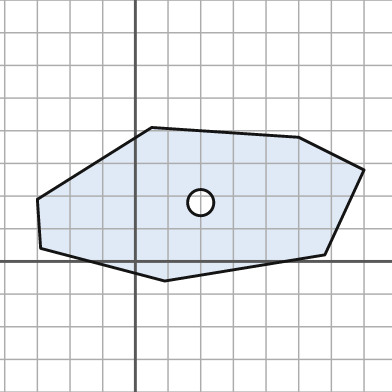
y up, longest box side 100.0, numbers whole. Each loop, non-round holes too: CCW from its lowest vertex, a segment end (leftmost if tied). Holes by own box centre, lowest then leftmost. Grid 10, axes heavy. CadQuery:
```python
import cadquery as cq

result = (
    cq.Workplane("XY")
    .moveTo(9.0, -6.0)
    .lineTo(58.0, 2.0)
    .lineTo(70.0, 28.0)
    .lineTo(50.0, 38.0)
    .lineTo(5.0, 41.0)
    .lineTo(-30.0, 19.0)
    .lineTo(-29.0, 4.0)
    .close()
    .moveTo(20.0, 18.0)
    .circle(4.0)
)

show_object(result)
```